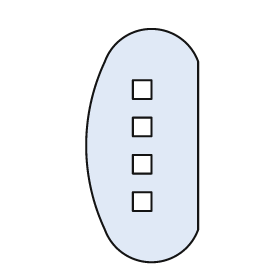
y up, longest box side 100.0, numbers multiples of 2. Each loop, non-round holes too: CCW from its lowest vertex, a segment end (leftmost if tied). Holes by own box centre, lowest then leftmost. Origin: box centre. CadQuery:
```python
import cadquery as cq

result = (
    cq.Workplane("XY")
    .moveTo(-16.0, -36.0)
    .threePointArc((4.0, -50.0), (24.0, -36.0))
    .lineTo(24.0, 36.0)
    .threePointArc((4.0, 50.0), (-16.0, 36.0))
    .threePointArc((-24.0, 0.0), (-16.0, -36.0))
    .close()
    .moveTo(-4.0, -28.0)
    .lineTo(4.0, -28.0)
    .lineTo(4.0, -20.0)
    .lineTo(-4.0, -20.0)
    .close()
    .moveTo(-4.0, -12.0)
    .lineTo(4.0, -12.0)
    .lineTo(4.0, -4.0)
    .lineTo(-4.0, -4.0)
    .close()
    .moveTo(-4.0, 4.0)
    .lineTo(4.0, 4.0)
    .lineTo(4.0, 12.0)
    .lineTo(-4.0, 12.0)
    .close()
    .moveTo(-4.0, 20.0)
    .lineTo(4.0, 20.0)
    .lineTo(4.0, 28.0)
    .lineTo(-4.0, 28.0)
    .close()
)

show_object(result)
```